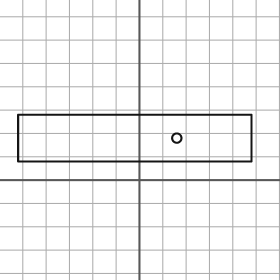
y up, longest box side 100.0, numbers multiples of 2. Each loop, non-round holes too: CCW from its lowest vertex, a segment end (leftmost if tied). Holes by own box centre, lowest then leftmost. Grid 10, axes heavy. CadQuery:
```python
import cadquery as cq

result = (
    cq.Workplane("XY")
    .moveTo(-52.0, 8.0)
    .lineTo(48.0, 8.0)
    .lineTo(48.0, 28.0)
    .lineTo(-52.0, 28.0)
    .close()
    .moveTo(16.0, 18.0)
    .circle(2.0)
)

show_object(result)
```